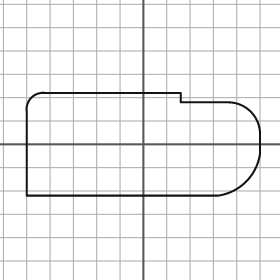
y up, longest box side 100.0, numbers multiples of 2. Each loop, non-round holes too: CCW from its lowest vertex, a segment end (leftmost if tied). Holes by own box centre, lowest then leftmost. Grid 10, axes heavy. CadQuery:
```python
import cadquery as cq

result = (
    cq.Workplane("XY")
    .moveTo(-50.0, -22.0)
    .lineTo(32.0, -22.0)
    .threePointArc((44.0, -16.0), (50.0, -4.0))
    .lineTo(50.0, 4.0)
    .threePointArc((46.0, 14.0), (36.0, 18.0))
    .lineTo(16.0, 18.0)
    .lineTo(16.0, 22.0)
    .lineTo(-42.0, 22.0)
    .threePointArc((-48.0, 20.0), (-50.0, 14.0))
    .close()
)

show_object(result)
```